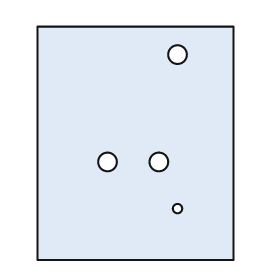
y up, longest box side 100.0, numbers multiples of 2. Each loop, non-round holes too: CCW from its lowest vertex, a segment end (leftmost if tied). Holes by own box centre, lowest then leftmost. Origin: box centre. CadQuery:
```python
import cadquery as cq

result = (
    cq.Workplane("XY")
    .moveTo(-42.0, -50.0)
    .lineTo(42.0, -50.0)
    .lineTo(42.0, 50.0)
    .lineTo(-42.0, 50.0)
    .close()
    .moveTo(18.0, -28.0)
    .circle(2.0)
    .moveTo(-12.0, -8.0)
    .circle(4.0)
    .moveTo(10.0, -8.0)
    .circle(4.0)
    .moveTo(18.0, 38.0)
    .circle(4.0)
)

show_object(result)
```